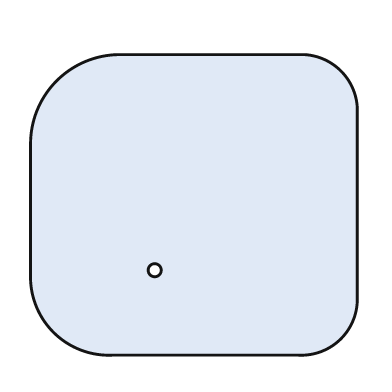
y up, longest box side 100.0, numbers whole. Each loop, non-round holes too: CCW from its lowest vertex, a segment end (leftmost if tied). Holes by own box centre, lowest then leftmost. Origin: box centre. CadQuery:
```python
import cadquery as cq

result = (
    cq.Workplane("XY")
    .moveTo(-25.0, -46.0)
    .lineTo(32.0, -46.0)
    .threePointArc((45.0, -41.0), (50.0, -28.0))
    .lineTo(50.0, 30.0)
    .threePointArc((45.0, 41.0), (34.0, 46.0))
    .lineTo(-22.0, 46.0)
    .threePointArc((-42.0, 38.0), (-50.0, 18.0))
    .lineTo(-50.0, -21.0)
    .threePointArc((-43.0, -39.0), (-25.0, -46.0))
    .close()
    .moveTo(-12.0, -20.0)
    .circle(2.0)
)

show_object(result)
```